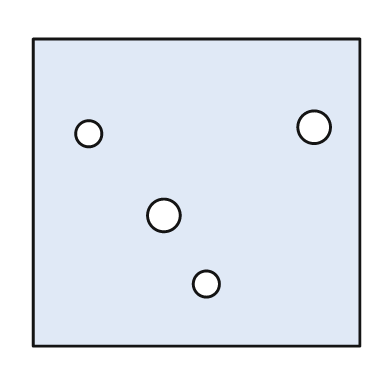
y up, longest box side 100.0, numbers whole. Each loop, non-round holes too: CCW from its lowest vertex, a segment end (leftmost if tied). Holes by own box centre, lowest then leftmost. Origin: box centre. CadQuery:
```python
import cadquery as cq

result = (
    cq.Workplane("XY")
    .moveTo(-50.0, -47.0)
    .lineTo(50.0, -47.0)
    .lineTo(50.0, 47.0)
    .lineTo(-50.0, 47.0)
    .close()
    .moveTo(3.0, -28.0)
    .circle(4.0)
    .moveTo(-10.0, -7.0)
    .circle(5.0)
    .moveTo(-33.0, 18.0)
    .circle(4.0)
    .moveTo(36.0, 20.0)
    .circle(5.0)
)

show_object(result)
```